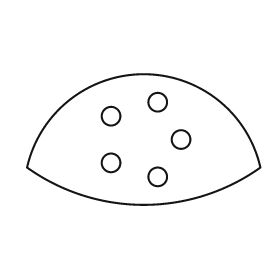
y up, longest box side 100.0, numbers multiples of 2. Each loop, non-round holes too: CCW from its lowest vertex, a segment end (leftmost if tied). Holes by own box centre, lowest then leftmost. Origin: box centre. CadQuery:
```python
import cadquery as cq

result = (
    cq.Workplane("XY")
    .moveTo(-50.0, -12.0)
    .threePointArc((0.0, -28.0), (50.0, -12.0))
    .threePointArc((0.0, 28.0), (-50.0, -12.0))
    .close()
    .moveTo(6.0, -16.0)
    .circle(4.0)
    .moveTo(-14.0, -10.0)
    .circle(4.0)
    .moveTo(16.0, 0.0)
    .circle(4.0)
    .moveTo(-14.0, 10.0)
    .circle(4.0)
    .moveTo(6.0, 16.0)
    .circle(4.0)
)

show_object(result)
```